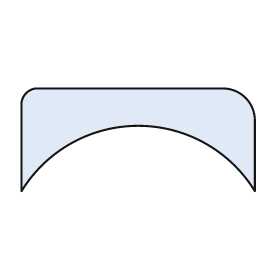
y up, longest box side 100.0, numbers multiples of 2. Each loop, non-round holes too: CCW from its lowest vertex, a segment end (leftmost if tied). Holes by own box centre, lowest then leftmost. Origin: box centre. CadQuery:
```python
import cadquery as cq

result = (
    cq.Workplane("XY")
    .moveTo(-50.0, -22.0)
    .threePointArc((0.0, 6.0), (50.0, -22.0))
    .lineTo(50.0, 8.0)
    .threePointArc((46.0, 18.0), (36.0, 22.0))
    .lineTo(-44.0, 22.0)
    .threePointArc((-48.0, 20.0), (-50.0, 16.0))
    .close()
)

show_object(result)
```